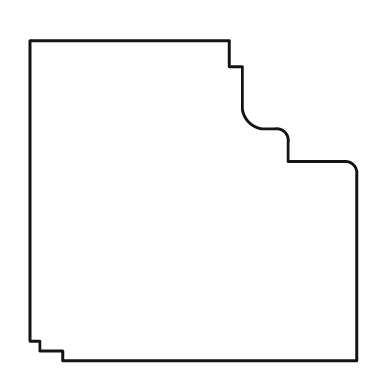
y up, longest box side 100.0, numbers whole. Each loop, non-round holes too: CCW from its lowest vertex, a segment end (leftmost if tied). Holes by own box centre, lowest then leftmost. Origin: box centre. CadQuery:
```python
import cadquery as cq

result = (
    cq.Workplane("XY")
    .moveTo(-40.0, -49.0)
    .lineTo(50.0, -49.0)
    .lineTo(50.0, 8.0)
    .threePointArc((49.0, 11.0), (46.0, 12.0))
    .lineTo(29.0, 12.0)
    .lineTo(29.0, 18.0)
    .threePointArc((28.0, 21.0), (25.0, 22.0))
    .lineTo(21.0, 22.0)
    .threePointArc((17.0, 24.0), (15.0, 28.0))
    .lineTo(15.0, 41.0)
    .lineTo(11.0, 41.0)
    .lineTo(11.0, 49.0)
    .lineTo(-50.0, 49.0)
    .lineTo(-50.0, -43.0)
    .lineTo(-47.0, -43.0)
    .lineTo(-47.0, -46.0)
    .lineTo(-40.0, -46.0)
    .close()
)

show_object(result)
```